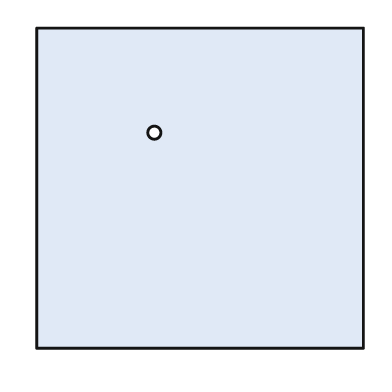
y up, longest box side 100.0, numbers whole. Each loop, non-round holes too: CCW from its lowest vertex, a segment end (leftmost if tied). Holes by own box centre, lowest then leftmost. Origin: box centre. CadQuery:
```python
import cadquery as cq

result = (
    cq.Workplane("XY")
    .moveTo(-50.0, -49.0)
    .lineTo(50.0, -49.0)
    .lineTo(50.0, 49.0)
    .lineTo(-50.0, 49.0)
    .close()
    .moveTo(-14.0, 17.0)
    .circle(2.0)
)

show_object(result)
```